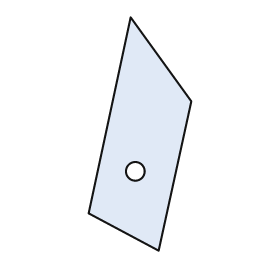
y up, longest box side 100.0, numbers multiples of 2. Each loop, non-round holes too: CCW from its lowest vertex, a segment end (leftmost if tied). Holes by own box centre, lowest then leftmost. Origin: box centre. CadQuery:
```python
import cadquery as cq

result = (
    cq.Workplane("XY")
    .moveTo(8.0, -50.0)
    .lineTo(22.0, 14.0)
    .lineTo(-4.0, 50.0)
    .lineTo(-22.0, -34.0)
    .close()
    .moveTo(-2.0, -16.0)
    .circle(4.0)
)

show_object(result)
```